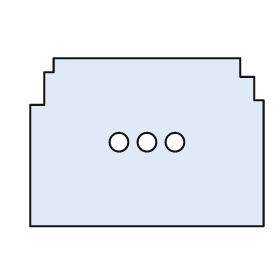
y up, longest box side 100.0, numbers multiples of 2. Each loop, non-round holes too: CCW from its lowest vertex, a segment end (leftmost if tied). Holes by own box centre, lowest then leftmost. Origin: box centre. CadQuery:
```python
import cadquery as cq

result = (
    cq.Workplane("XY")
    .moveTo(-50.0, -36.0)
    .lineTo(50.0, -36.0)
    .lineTo(50.0, 18.0)
    .lineTo(46.0, 18.0)
    .lineTo(46.0, 28.0)
    .lineTo(40.0, 28.0)
    .lineTo(40.0, 36.0)
    .lineTo(-40.0, 36.0)
    .lineTo(-40.0, 30.0)
    .lineTo(-44.0, 30.0)
    .lineTo(-44.0, 16.0)
    .lineTo(-50.0, 16.0)
    .close()
    .moveTo(-12.0, 0.0)
    .circle(4.0)
    .moveTo(0.0, 0.0)
    .circle(4.0)
    .moveTo(12.0, 0.0)
    .circle(4.0)
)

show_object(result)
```